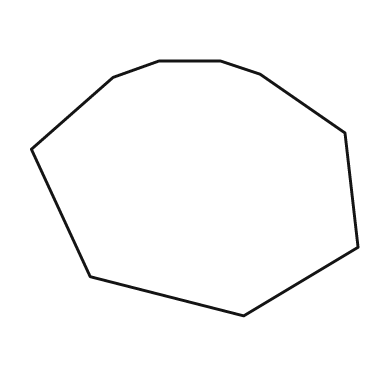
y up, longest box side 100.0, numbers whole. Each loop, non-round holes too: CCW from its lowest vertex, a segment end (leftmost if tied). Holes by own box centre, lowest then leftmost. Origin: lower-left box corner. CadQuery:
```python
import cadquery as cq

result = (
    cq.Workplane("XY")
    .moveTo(65.0, 0.0)
    .lineTo(100.0, 21.0)
    .lineTo(96.0, 56.0)
    .lineTo(70.0, 74.0)
    .lineTo(58.0, 78.0)
    .lineTo(39.0, 78.0)
    .lineTo(25.0, 73.0)
    .lineTo(0.0, 51.0)
    .lineTo(18.0, 12.0)
    .close()
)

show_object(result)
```